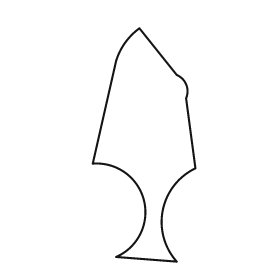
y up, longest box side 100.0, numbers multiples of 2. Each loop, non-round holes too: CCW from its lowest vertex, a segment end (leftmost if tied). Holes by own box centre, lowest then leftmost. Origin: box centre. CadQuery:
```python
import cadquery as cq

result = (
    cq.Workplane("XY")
    .moveTo(14.0, -50.0)
    .threePointArc((8.0, -28.0), (22.0, -10.0))
    .lineTo(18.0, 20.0)
    .threePointArc((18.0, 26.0), (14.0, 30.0))
    .lineTo(-2.0, 50.0)
    .threePointArc((-8.0, 44.0), (-12.0, 36.0))
    .lineTo(-22.0, -8.0)
    .threePointArc((0.0, -24.0), (-12.0, -48.0))
    .close()
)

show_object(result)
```